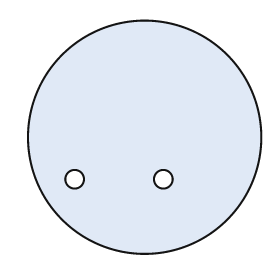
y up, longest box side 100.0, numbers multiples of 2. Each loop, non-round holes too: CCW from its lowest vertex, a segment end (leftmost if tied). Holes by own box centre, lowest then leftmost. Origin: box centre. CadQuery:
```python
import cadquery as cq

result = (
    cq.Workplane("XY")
    .moveTo(0.0, 0.0)
    .circle(50.0)
    .moveTo(-30.0, -18.0)
    .circle(4.0)
    .moveTo(8.0, -18.0)
    .circle(4.0)
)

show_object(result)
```